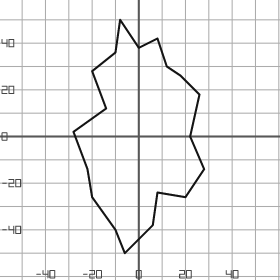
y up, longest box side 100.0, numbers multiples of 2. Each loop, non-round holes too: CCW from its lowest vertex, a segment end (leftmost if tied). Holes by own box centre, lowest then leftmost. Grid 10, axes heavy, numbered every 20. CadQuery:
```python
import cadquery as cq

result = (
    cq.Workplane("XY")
    .moveTo(-6.0, -50.0)
    .lineTo(6.0, -38.0)
    .lineTo(8.0, -24.0)
    .lineTo(20.0, -26.0)
    .lineTo(28.0, -14.0)
    .lineTo(22.0, 0.0)
    .lineTo(26.0, 18.0)
    .lineTo(18.0, 26.0)
    .lineTo(12.0, 30.0)
    .lineTo(8.0, 42.0)
    .lineTo(0.0, 38.0)
    .lineTo(-8.0, 50.0)
    .lineTo(-10.0, 36.0)
    .lineTo(-20.0, 28.0)
    .lineTo(-14.0, 12.0)
    .lineTo(-28.0, 2.0)
    .lineTo(-22.0, -14.0)
    .lineTo(-20.0, -26.0)
    .lineTo(-10.0, -40.0)
    .close()
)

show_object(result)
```